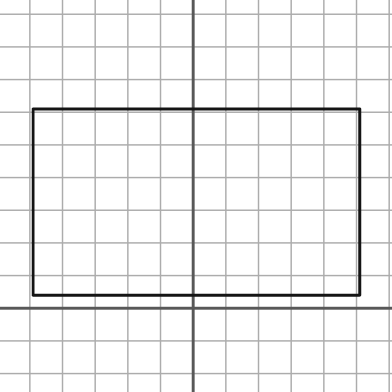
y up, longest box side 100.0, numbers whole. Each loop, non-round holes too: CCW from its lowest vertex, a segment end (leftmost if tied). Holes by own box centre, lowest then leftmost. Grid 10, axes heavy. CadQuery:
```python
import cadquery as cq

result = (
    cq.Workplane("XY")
    .moveTo(-49.0, 4.0)
    .lineTo(51.0, 4.0)
    .lineTo(51.0, 61.0)
    .lineTo(-49.0, 61.0)
    .close()
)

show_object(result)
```